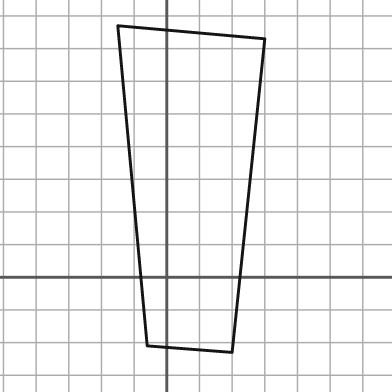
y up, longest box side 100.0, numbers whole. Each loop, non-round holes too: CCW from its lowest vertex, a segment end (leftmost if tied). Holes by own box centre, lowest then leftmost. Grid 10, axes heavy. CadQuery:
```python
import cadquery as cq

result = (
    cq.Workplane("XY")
    .moveTo(20.0, -23.0)
    .lineTo(30.0, 73.0)
    .lineTo(-15.0, 77.0)
    .lineTo(-6.0, -21.0)
    .close()
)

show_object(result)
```